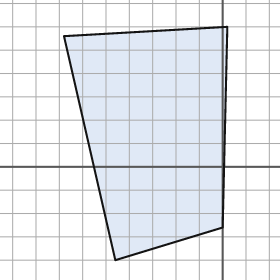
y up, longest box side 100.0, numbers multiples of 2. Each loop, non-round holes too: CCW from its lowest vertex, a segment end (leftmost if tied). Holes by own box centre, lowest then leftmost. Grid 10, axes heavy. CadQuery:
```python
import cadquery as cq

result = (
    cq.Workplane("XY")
    .moveTo(-46.0, -40.0)
    .lineTo(0.0, -26.0)
    .lineTo(2.0, 60.0)
    .lineTo(-68.0, 56.0)
    .close()
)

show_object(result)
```